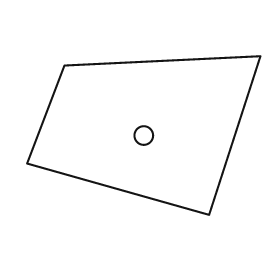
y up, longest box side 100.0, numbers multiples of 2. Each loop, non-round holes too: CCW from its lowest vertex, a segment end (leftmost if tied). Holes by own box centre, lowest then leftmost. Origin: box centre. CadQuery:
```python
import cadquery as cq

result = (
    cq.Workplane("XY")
    .moveTo(28.0, -34.0)
    .lineTo(50.0, 34.0)
    .lineTo(-34.0, 30.0)
    .lineTo(-50.0, -12.0)
    .close()
    .moveTo(0.0, 0.0)
    .circle(4.0)
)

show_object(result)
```